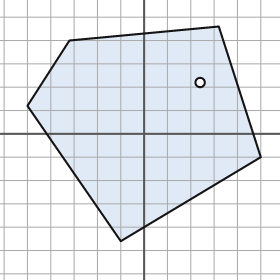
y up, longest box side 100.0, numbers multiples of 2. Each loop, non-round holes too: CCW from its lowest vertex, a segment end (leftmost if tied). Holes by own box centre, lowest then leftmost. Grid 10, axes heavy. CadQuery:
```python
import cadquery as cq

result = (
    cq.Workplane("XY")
    .moveTo(-10.0, -46.0)
    .lineTo(50.0, -10.0)
    .lineTo(32.0, 46.0)
    .lineTo(-32.0, 40.0)
    .lineTo(-50.0, 12.0)
    .close()
    .moveTo(24.0, 22.0)
    .circle(2.0)
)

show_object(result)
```